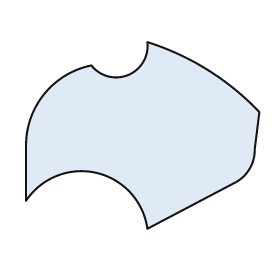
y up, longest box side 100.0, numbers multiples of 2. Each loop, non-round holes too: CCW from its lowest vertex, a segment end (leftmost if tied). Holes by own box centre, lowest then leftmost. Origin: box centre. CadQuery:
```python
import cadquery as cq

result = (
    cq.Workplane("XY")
    .moveTo(2.0, -40.0)
    .lineTo(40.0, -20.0)
    .threePointArc((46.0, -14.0), (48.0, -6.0))
    .lineTo(50.0, 10.0)
    .threePointArc((28.0, 28.0), (2.0, 40.0))
    .threePointArc((-6.0, 26.0), (-22.0, 30.0))
    .threePointArc((-42.0, 18.0), (-50.0, -4.0))
    .lineTo(-50.0, -28.0)
    .threePointArc((-20.0, -16.0), (2.0, -40.0))
    .close()
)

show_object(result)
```